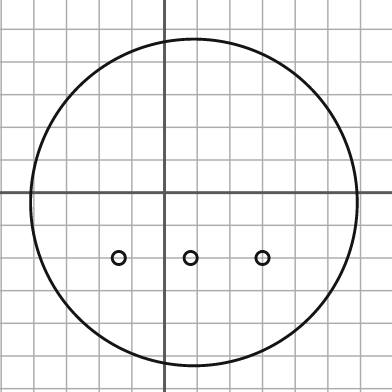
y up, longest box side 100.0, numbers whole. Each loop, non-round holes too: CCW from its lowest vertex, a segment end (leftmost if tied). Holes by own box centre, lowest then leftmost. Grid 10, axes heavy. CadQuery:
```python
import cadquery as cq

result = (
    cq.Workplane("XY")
    .moveTo(9.0, -3.0)
    .circle(50.0)
    .moveTo(-14.0, -20.0)
    .circle(2.0)
    .moveTo(8.0, -20.0)
    .circle(2.0)
    .moveTo(30.0, -20.0)
    .circle(2.0)
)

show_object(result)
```